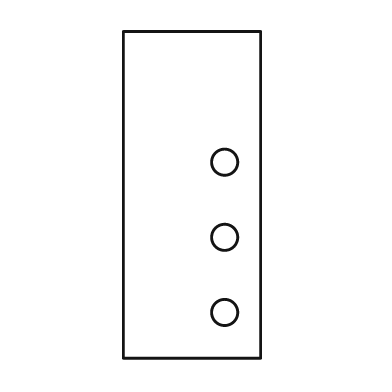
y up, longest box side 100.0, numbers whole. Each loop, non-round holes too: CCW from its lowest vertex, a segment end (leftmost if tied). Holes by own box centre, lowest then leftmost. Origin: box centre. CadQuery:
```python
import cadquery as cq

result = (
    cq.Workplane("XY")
    .moveTo(-21.0, -50.0)
    .lineTo(21.0, -50.0)
    .lineTo(21.0, 50.0)
    .lineTo(-21.0, 50.0)
    .close()
    .moveTo(10.0, -36.0)
    .circle(4.0)
    .moveTo(10.0, -13.0)
    .circle(4.0)
    .moveTo(10.0, 10.0)
    .circle(4.0)
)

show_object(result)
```